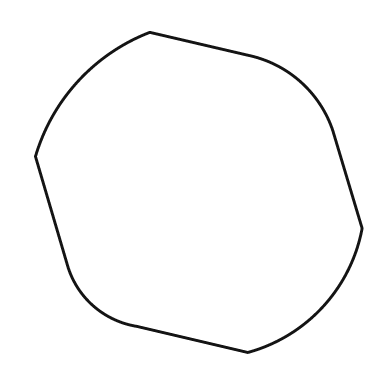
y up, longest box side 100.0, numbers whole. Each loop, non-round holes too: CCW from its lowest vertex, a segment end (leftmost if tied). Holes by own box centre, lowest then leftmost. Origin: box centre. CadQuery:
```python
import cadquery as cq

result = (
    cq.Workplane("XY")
    .moveTo(15.0, -49.0)
    .threePointArc((38.0, -35.0), (50.0, -11.0))
    .lineTo(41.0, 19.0)
    .threePointArc((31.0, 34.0), (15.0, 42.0))
    .lineTo(-15.0, 49.0)
    .threePointArc((-37.0, 34.0), (-50.0, 11.0))
    .lineTo(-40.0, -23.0)
    .threePointArc((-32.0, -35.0), (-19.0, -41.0))
    .close()
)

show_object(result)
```